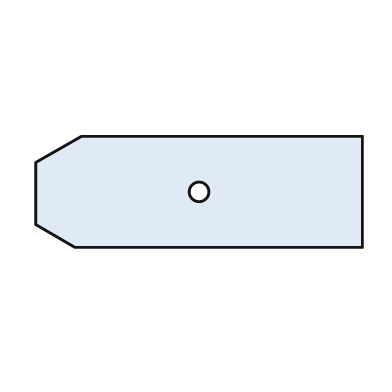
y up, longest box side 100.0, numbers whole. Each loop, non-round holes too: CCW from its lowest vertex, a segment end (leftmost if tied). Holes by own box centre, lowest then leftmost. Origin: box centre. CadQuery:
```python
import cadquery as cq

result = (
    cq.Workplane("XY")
    .moveTo(-38.0, -17.0)
    .lineTo(50.0, -17.0)
    .lineTo(50.0, 17.0)
    .lineTo(-36.0, 17.0)
    .lineTo(-50.0, 9.0)
    .lineTo(-50.0, -10.0)
    .close()
    .moveTo(0.0, 0.0)
    .circle(3.0)
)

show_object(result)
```